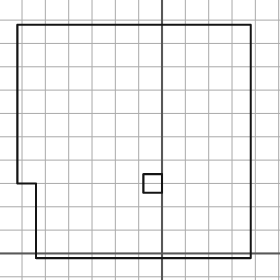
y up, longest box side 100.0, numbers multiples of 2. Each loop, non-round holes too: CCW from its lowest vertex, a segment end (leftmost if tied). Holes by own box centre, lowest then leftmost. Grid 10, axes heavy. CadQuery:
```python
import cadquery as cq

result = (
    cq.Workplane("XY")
    .moveTo(-54.0, -2.0)
    .lineTo(38.0, -2.0)
    .lineTo(38.0, 98.0)
    .lineTo(-62.0, 98.0)
    .lineTo(-62.0, 30.0)
    .lineTo(-54.0, 30.0)
    .close()
    .moveTo(-8.0, 26.0)
    .lineTo(0.0, 26.0)
    .lineTo(0.0, 34.0)
    .lineTo(-8.0, 34.0)
    .close()
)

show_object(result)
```